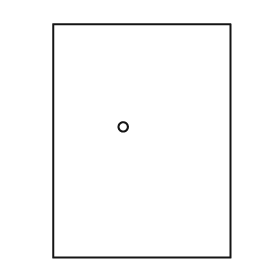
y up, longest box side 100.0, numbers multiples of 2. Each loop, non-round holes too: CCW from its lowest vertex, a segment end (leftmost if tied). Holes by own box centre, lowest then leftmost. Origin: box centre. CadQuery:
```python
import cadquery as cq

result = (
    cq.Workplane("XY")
    .moveTo(-38.0, -50.0)
    .lineTo(38.0, -50.0)
    .lineTo(38.0, 50.0)
    .lineTo(-38.0, 50.0)
    .close()
    .moveTo(-8.0, 6.0)
    .circle(2.0)
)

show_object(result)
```